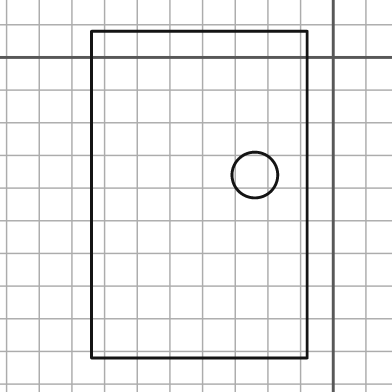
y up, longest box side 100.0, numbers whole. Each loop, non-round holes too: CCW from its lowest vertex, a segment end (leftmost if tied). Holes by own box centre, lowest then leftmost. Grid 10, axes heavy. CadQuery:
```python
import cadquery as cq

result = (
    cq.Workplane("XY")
    .moveTo(-74.0, -92.0)
    .lineTo(-8.0, -92.0)
    .lineTo(-8.0, 8.0)
    .lineTo(-74.0, 8.0)
    .close()
    .moveTo(-24.0, -36.0)
    .circle(7.0)
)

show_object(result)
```